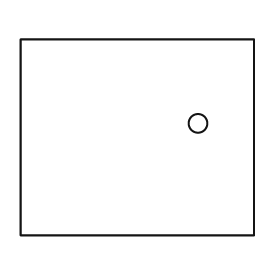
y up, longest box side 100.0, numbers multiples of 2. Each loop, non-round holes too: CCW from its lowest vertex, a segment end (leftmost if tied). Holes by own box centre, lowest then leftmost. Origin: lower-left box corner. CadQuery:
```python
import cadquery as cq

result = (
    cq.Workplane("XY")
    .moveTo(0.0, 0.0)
    .lineTo(100.0, 0.0)
    .lineTo(100.0, 84.0)
    .lineTo(0.0, 84.0)
    .close()
    .moveTo(76.0, 48.0)
    .circle(4.0)
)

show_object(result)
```